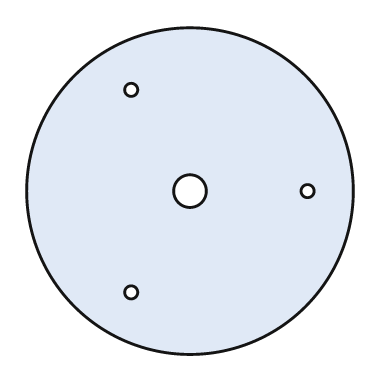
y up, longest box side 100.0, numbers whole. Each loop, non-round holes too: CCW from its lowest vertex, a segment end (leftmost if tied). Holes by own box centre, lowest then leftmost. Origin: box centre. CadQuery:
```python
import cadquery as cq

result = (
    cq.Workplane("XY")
    .moveTo(0.0, 0.0)
    .circle(50.0)
    .moveTo(-18.0, -31.0)
    .circle(2.0)
    .moveTo(0.0, 0.0)
    .circle(5.0)
    .moveTo(36.0, 0.0)
    .circle(2.0)
    .moveTo(-18.0, 31.0)
    .circle(2.0)
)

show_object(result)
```